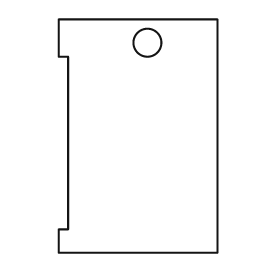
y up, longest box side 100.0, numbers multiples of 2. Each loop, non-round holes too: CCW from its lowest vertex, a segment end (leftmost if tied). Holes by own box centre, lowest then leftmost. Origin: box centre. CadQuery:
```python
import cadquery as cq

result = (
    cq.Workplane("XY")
    .moveTo(-34.0, -50.0)
    .lineTo(34.0, -50.0)
    .lineTo(34.0, 50.0)
    .lineTo(-34.0, 50.0)
    .lineTo(-34.0, 34.0)
    .lineTo(-30.0, 34.0)
    .lineTo(-30.0, -40.0)
    .lineTo(-34.0, -40.0)
    .close()
    .moveTo(4.0, 40.0)
    .circle(6.0)
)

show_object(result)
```